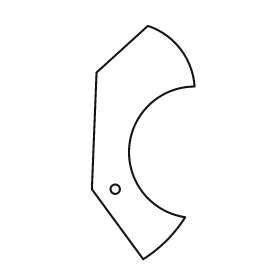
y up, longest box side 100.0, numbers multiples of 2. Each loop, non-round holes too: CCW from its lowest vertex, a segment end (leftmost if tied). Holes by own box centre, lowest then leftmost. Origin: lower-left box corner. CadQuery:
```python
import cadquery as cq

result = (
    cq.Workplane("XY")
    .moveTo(22.0, 0.0)
    .threePointArc((32.0, 8.0), (40.0, 18.0))
    .threePointArc((16.0, 48.0), (44.0, 74.0))
    .threePointArc((38.0, 90.0), (24.0, 100.0))
    .lineTo(2.0, 80.0)
    .lineTo(0.0, 30.0)
    .close()
    .moveTo(10.0, 30.0)
    .circle(2.0)
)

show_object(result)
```